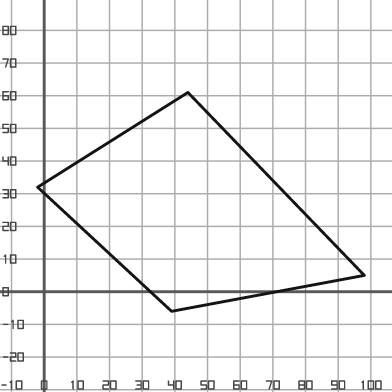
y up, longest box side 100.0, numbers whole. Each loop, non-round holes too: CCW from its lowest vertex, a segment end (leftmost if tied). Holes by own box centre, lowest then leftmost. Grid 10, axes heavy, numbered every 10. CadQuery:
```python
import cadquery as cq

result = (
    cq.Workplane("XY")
    .moveTo(39.0, -6.0)
    .lineTo(98.0, 5.0)
    .lineTo(44.0, 61.0)
    .lineTo(-2.0, 32.0)
    .close()
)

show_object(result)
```